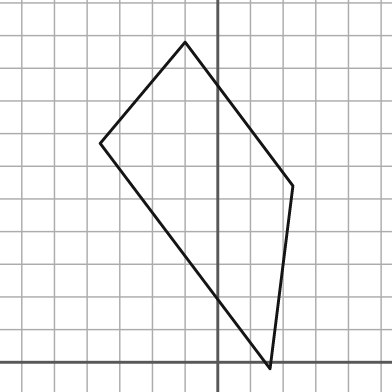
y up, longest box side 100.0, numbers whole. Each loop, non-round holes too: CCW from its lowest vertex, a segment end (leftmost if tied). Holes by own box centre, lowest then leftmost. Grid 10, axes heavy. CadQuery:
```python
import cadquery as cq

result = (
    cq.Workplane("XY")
    .moveTo(16.0, -2.0)
    .lineTo(23.0, 54.0)
    .lineTo(-10.0, 98.0)
    .lineTo(-36.0, 67.0)
    .close()
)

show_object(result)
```